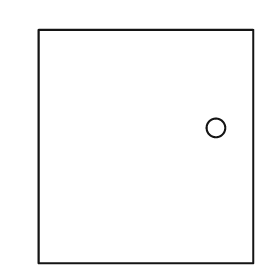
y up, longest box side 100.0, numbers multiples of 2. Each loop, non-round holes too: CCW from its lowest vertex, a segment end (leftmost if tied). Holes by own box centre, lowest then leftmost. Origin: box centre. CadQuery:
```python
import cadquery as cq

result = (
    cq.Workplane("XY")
    .moveTo(-46.0, -50.0)
    .lineTo(46.0, -50.0)
    .lineTo(46.0, 50.0)
    .lineTo(-46.0, 50.0)
    .close()
    .moveTo(30.0, 8.0)
    .circle(4.0)
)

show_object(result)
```